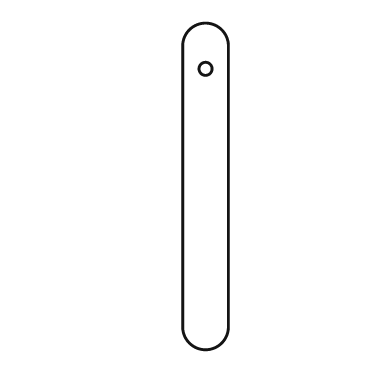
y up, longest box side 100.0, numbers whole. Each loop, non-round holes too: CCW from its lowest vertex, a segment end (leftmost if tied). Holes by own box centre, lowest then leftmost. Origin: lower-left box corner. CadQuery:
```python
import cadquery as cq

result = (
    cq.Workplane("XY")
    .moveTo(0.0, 7.0)
    .threePointArc((7.0, 0.0), (14.0, 7.0))
    .lineTo(14.0, 93.0)
    .threePointArc((7.0, 100.0), (0.0, 93.0))
    .close()
    .moveTo(7.0, 86.0)
    .circle(2.0)
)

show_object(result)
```